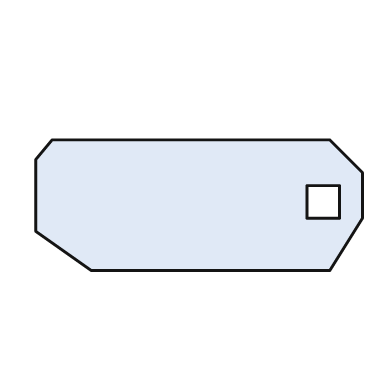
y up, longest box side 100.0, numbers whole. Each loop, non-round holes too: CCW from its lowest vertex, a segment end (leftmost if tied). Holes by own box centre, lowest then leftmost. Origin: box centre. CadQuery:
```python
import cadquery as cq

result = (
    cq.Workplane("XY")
    .moveTo(-33.0, -20.0)
    .lineTo(40.0, -20.0)
    .lineTo(50.0, -4.0)
    .lineTo(50.0, 10.0)
    .lineTo(40.0, 20.0)
    .lineTo(-45.0, 20.0)
    .lineTo(-50.0, 14.0)
    .lineTo(-50.0, -8.0)
    .close()
    .moveTo(33.0, -4.0)
    .lineTo(43.0, -4.0)
    .lineTo(43.0, 6.0)
    .lineTo(33.0, 6.0)
    .close()
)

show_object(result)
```